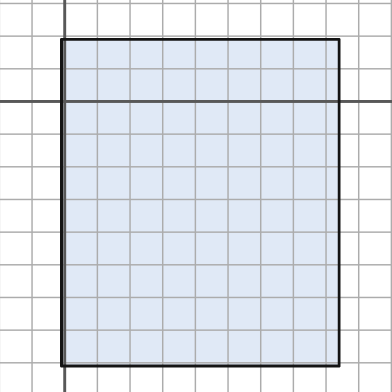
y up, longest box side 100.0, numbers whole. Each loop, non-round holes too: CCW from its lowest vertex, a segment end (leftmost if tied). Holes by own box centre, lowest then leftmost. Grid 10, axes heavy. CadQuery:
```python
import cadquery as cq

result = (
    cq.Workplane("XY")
    .moveTo(-1.0, -81.0)
    .lineTo(84.0, -81.0)
    .lineTo(84.0, 19.0)
    .lineTo(-1.0, 19.0)
    .close()
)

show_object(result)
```